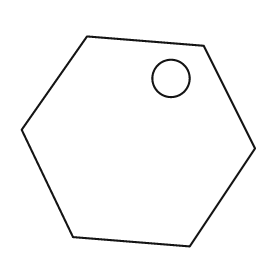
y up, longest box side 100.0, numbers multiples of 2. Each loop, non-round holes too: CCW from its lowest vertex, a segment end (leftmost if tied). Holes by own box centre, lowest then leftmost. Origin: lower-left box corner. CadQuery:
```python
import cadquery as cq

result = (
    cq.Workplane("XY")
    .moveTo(72.0, 0.0)
    .lineTo(100.0, 42.0)
    .lineTo(78.0, 86.0)
    .lineTo(28.0, 90.0)
    .lineTo(0.0, 50.0)
    .lineTo(22.0, 4.0)
    .close()
    .moveTo(64.0, 72.0)
    .circle(8.0)
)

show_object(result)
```